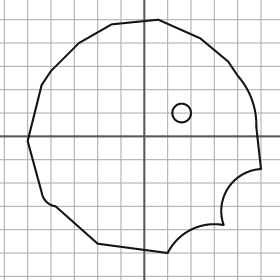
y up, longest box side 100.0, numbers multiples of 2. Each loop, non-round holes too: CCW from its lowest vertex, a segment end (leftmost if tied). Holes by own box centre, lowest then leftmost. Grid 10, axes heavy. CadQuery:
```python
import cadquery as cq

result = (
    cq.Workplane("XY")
    .moveTo(10.0, -50.0)
    .threePointArc((20.0, -40.0), (34.0, -38.0))
    .threePointArc((36.0, -22.0), (50.0, -14.0))
    .lineTo(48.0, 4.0)
    .threePointArc((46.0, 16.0), (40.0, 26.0))
    .lineTo(36.0, 32.0)
    .lineTo(24.0, 42.0)
    .lineTo(6.0, 50.0)
    .lineTo(-14.0, 48.0)
    .lineTo(-28.0, 40.0)
    .lineTo(-40.0, 28.0)
    .lineTo(-44.0, 22.0)
    .lineTo(-50.0, -2.0)
    .lineTo(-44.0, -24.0)
    .threePointArc((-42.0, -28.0), (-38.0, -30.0))
    .lineTo(-20.0, -46.0)
    .close()
    .moveTo(16.0, 10.0)
    .circle(4.0)
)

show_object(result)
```